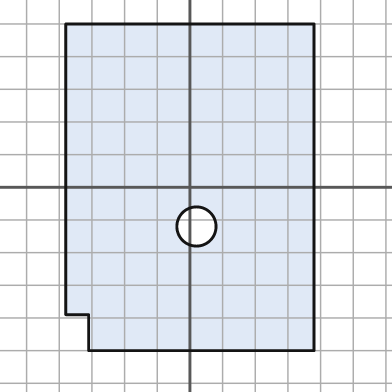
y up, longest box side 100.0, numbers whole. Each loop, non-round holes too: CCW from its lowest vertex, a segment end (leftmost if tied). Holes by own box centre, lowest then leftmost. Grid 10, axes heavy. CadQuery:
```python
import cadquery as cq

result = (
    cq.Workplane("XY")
    .moveTo(-31.0, -50.0)
    .lineTo(38.0, -50.0)
    .lineTo(38.0, 50.0)
    .lineTo(-38.0, 50.0)
    .lineTo(-38.0, -39.0)
    .lineTo(-31.0, -39.0)
    .close()
    .moveTo(2.0, -12.0)
    .circle(6.0)
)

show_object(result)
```